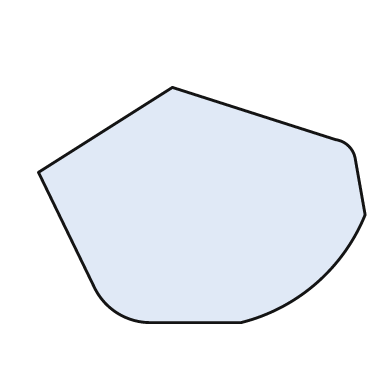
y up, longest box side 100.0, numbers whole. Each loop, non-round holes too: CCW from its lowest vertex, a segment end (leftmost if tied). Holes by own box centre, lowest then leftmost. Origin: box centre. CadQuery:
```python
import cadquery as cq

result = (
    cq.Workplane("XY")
    .moveTo(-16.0, -36.0)
    .lineTo(12.0, -36.0)
    .threePointArc((35.0, -24.0), (50.0, -3.0))
    .lineTo(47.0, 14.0)
    .threePointArc((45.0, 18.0), (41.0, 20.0))
    .lineTo(-9.0, 36.0)
    .lineTo(-50.0, 10.0)
    .lineTo(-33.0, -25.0)
    .threePointArc((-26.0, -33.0), (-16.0, -36.0))
    .close()
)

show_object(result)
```